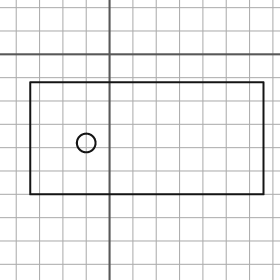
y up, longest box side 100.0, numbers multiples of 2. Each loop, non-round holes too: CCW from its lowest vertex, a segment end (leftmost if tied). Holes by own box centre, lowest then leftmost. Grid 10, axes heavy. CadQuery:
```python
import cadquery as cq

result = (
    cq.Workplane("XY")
    .moveTo(-34.0, -60.0)
    .lineTo(66.0, -60.0)
    .lineTo(66.0, -12.0)
    .lineTo(-34.0, -12.0)
    .close()
    .moveTo(-10.0, -38.0)
    .circle(4.0)
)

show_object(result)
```